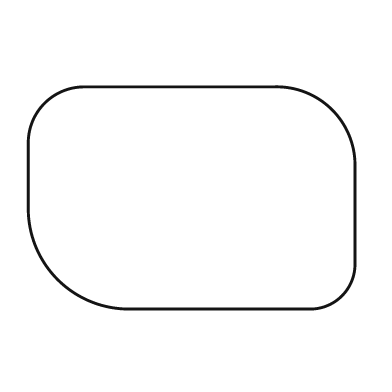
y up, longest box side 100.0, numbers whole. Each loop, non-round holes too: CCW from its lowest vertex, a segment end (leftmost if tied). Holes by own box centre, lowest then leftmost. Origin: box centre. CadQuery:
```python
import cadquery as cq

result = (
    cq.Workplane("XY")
    .moveTo(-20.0, -34.0)
    .lineTo(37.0, -34.0)
    .threePointArc((46.0, -30.0), (50.0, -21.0))
    .lineTo(50.0, 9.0)
    .threePointArc((43.0, 27.0), (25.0, 34.0))
    .lineTo(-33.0, 34.0)
    .threePointArc((-45.0, 29.0), (-50.0, 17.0))
    .lineTo(-50.0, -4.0)
    .threePointArc((-41.0, -25.0), (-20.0, -34.0))
    .close()
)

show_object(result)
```